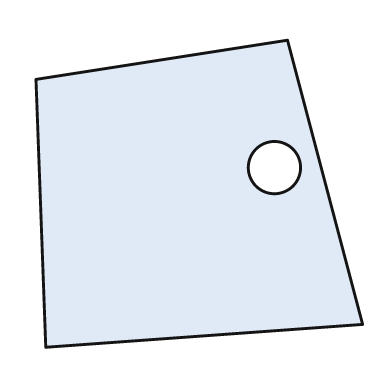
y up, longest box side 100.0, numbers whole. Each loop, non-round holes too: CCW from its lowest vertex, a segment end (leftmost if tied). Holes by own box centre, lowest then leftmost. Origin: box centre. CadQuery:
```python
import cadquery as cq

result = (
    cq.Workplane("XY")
    .moveTo(-47.0, -47.0)
    .lineTo(50.0, -40.0)
    .lineTo(27.0, 47.0)
    .lineTo(-50.0, 35.0)
    .close()
    .moveTo(23.0, 8.0)
    .circle(8.0)
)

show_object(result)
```